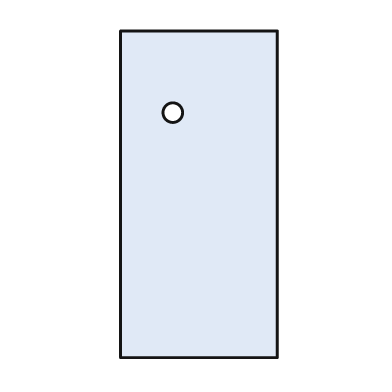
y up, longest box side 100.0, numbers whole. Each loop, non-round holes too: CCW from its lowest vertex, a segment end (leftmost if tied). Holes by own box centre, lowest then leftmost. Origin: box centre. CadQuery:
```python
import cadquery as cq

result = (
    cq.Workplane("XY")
    .moveTo(-24.0, -50.0)
    .lineTo(24.0, -50.0)
    .lineTo(24.0, 50.0)
    .lineTo(-24.0, 50.0)
    .close()
    .moveTo(-8.0, 25.0)
    .circle(3.0)
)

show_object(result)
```